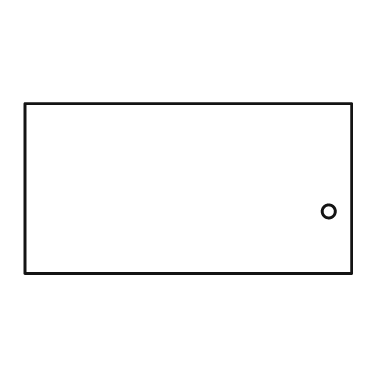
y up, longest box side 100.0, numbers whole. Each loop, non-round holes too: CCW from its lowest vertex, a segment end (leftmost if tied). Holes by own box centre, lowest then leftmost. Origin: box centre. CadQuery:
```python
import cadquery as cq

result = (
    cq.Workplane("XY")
    .moveTo(-50.0, -26.0)
    .lineTo(50.0, -26.0)
    .lineTo(50.0, 26.0)
    .lineTo(-50.0, 26.0)
    .close()
    .moveTo(43.0, -7.0)
    .circle(2.0)
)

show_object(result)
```